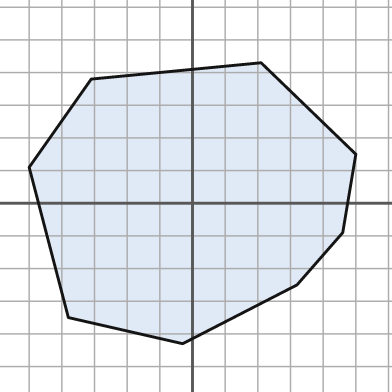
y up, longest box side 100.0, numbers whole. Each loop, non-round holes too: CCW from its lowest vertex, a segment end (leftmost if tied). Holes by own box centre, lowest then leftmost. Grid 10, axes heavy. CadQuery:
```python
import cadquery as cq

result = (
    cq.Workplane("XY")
    .moveTo(-3.0, -43.0)
    .lineTo(32.0, -25.0)
    .lineTo(46.0, -9.0)
    .lineTo(50.0, 15.0)
    .lineTo(21.0, 43.0)
    .lineTo(-31.0, 38.0)
    .lineTo(-50.0, 11.0)
    .lineTo(-38.0, -35.0)
    .close()
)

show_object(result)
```